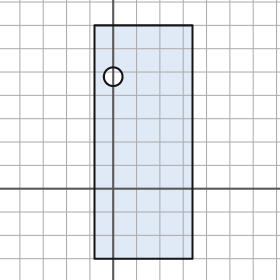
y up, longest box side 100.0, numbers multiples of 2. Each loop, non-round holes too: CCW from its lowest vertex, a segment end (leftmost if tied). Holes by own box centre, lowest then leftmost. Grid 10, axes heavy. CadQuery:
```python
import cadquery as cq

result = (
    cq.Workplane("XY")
    .moveTo(-8.0, -30.0)
    .lineTo(34.0, -30.0)
    .lineTo(34.0, 70.0)
    .lineTo(-8.0, 70.0)
    .close()
    .moveTo(0.0, 48.0)
    .circle(4.0)
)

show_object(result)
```